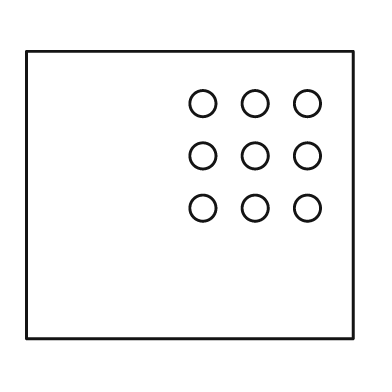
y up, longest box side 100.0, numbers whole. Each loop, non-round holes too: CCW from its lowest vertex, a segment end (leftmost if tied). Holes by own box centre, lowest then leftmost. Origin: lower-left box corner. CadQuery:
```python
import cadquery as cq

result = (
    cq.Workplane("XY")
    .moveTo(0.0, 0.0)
    .lineTo(100.0, 0.0)
    .lineTo(100.0, 88.0)
    .lineTo(0.0, 88.0)
    .close()
    .moveTo(54.0, 40.0)
    .circle(4.0)
    .moveTo(70.0, 40.0)
    .circle(4.0)
    .moveTo(86.0, 40.0)
    .circle(4.0)
    .moveTo(54.0, 56.0)
    .circle(4.0)
    .moveTo(70.0, 56.0)
    .circle(4.0)
    .moveTo(86.0, 56.0)
    .circle(4.0)
    .moveTo(54.0, 72.0)
    .circle(4.0)
    .moveTo(70.0, 72.0)
    .circle(4.0)
    .moveTo(86.0, 72.0)
    .circle(4.0)
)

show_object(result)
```